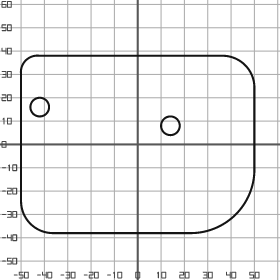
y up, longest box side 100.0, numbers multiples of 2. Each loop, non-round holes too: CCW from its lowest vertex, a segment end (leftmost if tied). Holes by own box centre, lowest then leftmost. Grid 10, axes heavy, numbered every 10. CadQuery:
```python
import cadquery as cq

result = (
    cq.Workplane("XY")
    .moveTo(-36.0, -38.0)
    .lineTo(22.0, -38.0)
    .threePointArc((42.0, -30.0), (50.0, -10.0))
    .lineTo(50.0, 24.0)
    .threePointArc((46.0, 34.0), (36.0, 38.0))
    .lineTo(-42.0, 38.0)
    .threePointArc((-48.0, 36.0), (-50.0, 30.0))
    .lineTo(-50.0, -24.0)
    .threePointArc((-46.0, -34.0), (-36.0, -38.0))
    .close()
    .moveTo(14.0, 8.0)
    .circle(4.0)
    .moveTo(-42.0, 16.0)
    .circle(4.0)
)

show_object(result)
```